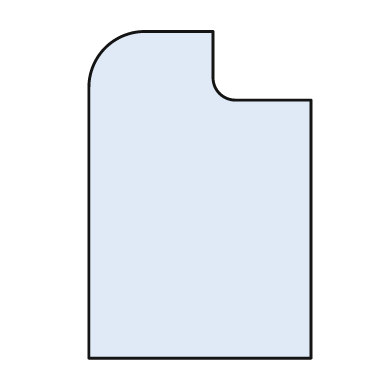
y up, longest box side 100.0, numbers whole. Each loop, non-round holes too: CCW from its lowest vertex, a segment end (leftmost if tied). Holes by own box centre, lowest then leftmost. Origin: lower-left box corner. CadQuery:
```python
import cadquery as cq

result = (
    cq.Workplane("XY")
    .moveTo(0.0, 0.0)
    .lineTo(68.0, 0.0)
    .lineTo(68.0, 79.0)
    .lineTo(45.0, 79.0)
    .threePointArc((40.0, 81.0), (38.0, 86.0))
    .lineTo(38.0, 100.0)
    .lineTo(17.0, 100.0)
    .threePointArc((5.0, 95.0), (0.0, 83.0))
    .close()
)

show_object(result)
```